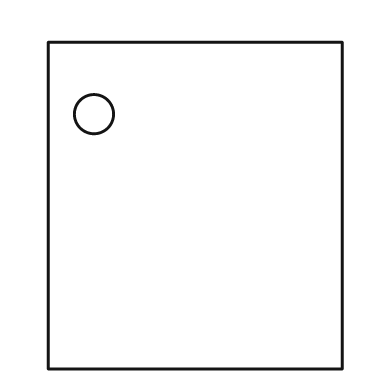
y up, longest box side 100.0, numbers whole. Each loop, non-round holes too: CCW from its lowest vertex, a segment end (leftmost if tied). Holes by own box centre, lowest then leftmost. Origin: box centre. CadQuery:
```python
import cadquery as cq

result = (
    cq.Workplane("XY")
    .moveTo(-45.0, -50.0)
    .lineTo(45.0, -50.0)
    .lineTo(45.0, 50.0)
    .lineTo(-45.0, 50.0)
    .close()
    .moveTo(-31.0, 28.0)
    .circle(6.0)
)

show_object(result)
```